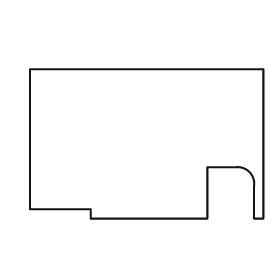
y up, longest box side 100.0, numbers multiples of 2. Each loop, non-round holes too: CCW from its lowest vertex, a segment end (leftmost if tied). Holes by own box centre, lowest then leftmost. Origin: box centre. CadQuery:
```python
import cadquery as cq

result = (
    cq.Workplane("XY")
    .moveTo(-24.0, -32.0)
    .lineTo(26.0, -32.0)
    .lineTo(26.0, -10.0)
    .lineTo(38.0, -10.0)
    .threePointArc((44.0, -12.0), (46.0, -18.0))
    .lineTo(46.0, -32.0)
    .lineTo(50.0, -32.0)
    .lineTo(50.0, 32.0)
    .lineTo(-50.0, 32.0)
    .lineTo(-50.0, -28.0)
    .lineTo(-24.0, -28.0)
    .close()
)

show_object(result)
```